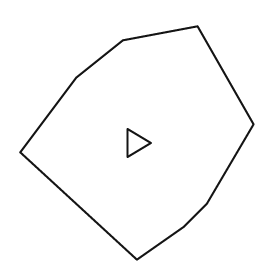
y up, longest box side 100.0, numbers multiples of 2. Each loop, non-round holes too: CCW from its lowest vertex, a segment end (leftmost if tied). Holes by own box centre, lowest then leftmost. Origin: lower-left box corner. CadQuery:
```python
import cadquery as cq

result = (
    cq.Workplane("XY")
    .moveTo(50.0, 0.0)
    .lineTo(70.0, 14.0)
    .lineTo(80.0, 24.0)
    .lineTo(100.0, 58.0)
    .lineTo(76.0, 100.0)
    .lineTo(44.0, 94.0)
    .lineTo(24.0, 78.0)
    .lineTo(0.0, 46.0)
    .close()
    .moveTo(46.0, 44.0)
    .lineTo(56.0, 50.0)
    .lineTo(46.0, 56.0)
    .close()
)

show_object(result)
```